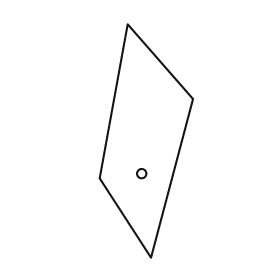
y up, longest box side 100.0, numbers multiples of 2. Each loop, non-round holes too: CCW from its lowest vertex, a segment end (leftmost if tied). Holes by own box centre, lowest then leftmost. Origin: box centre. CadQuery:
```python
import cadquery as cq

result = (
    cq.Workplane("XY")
    .moveTo(2.0, -50.0)
    .lineTo(20.0, 18.0)
    .lineTo(-8.0, 50.0)
    .lineTo(-20.0, -16.0)
    .close()
    .moveTo(-2.0, -14.0)
    .circle(2.0)
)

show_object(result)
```